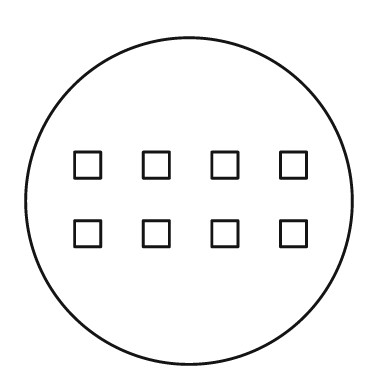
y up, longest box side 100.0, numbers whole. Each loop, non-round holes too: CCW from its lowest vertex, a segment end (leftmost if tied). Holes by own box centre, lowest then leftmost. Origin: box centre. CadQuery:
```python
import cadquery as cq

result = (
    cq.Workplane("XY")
    .moveTo(0.0, 0.0)
    .circle(50.0)
    .moveTo(-35.0, -14.0)
    .lineTo(-27.0, -14.0)
    .lineTo(-27.0, -6.0)
    .lineTo(-35.0, -6.0)
    .close()
    .moveTo(-14.0, -14.0)
    .lineTo(-6.0, -14.0)
    .lineTo(-6.0, -6.0)
    .lineTo(-14.0, -6.0)
    .close()
    .moveTo(7.0, -14.0)
    .lineTo(15.0, -14.0)
    .lineTo(15.0, -6.0)
    .lineTo(7.0, -6.0)
    .close()
    .moveTo(28.0, -14.0)
    .lineTo(36.0, -14.0)
    .lineTo(36.0, -6.0)
    .lineTo(28.0, -6.0)
    .close()
    .moveTo(-35.0, 7.0)
    .lineTo(-27.0, 7.0)
    .lineTo(-27.0, 15.0)
    .lineTo(-35.0, 15.0)
    .close()
    .moveTo(-14.0, 7.0)
    .lineTo(-6.0, 7.0)
    .lineTo(-6.0, 15.0)
    .lineTo(-14.0, 15.0)
    .close()
    .moveTo(7.0, 7.0)
    .lineTo(15.0, 7.0)
    .lineTo(15.0, 15.0)
    .lineTo(7.0, 15.0)
    .close()
    .moveTo(28.0, 7.0)
    .lineTo(36.0, 7.0)
    .lineTo(36.0, 15.0)
    .lineTo(28.0, 15.0)
    .close()
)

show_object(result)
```